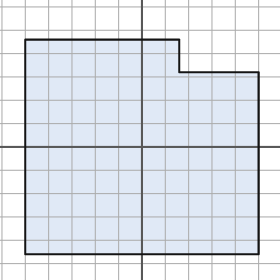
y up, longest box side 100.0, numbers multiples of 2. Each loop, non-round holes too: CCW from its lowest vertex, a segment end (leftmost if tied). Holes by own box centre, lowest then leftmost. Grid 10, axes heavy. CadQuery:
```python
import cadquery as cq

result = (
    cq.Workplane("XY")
    .moveTo(-50.0, -46.0)
    .lineTo(50.0, -46.0)
    .lineTo(50.0, 32.0)
    .lineTo(16.0, 32.0)
    .lineTo(16.0, 46.0)
    .lineTo(-50.0, 46.0)
    .close()
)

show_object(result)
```